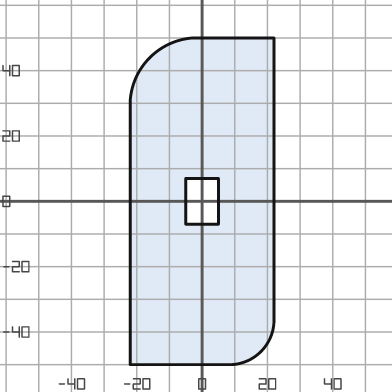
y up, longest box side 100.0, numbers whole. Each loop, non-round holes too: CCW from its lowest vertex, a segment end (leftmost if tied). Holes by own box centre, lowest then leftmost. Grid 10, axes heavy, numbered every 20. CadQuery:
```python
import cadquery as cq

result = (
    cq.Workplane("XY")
    .moveTo(-22.0, -50.0)
    .lineTo(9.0, -50.0)
    .threePointArc((18.0, -46.0), (22.0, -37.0))
    .lineTo(22.0, 50.0)
    .lineTo(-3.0, 50.0)
    .threePointArc((-16.0, 44.0), (-22.0, 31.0))
    .close()
    .moveTo(-5.0, -7.0)
    .lineTo(5.0, -7.0)
    .lineTo(5.0, 7.0)
    .lineTo(-5.0, 7.0)
    .close()
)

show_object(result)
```